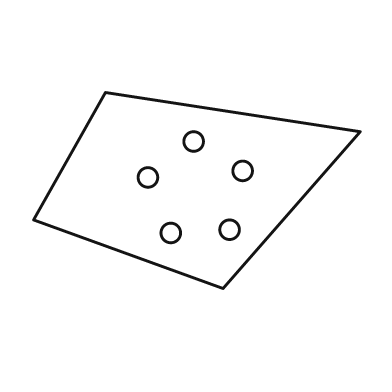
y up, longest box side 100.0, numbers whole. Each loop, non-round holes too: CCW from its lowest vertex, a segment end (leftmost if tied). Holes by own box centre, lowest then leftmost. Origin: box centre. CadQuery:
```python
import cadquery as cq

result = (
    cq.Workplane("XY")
    .moveTo(8.0, -30.0)
    .lineTo(50.0, 18.0)
    .lineTo(-28.0, 30.0)
    .lineTo(-50.0, -9.0)
    .close()
    .moveTo(-8.0, -13.0)
    .circle(3.0)
    .moveTo(10.0, -12.0)
    .circle(3.0)
    .moveTo(-15.0, 4.0)
    .circle(3.0)
    .moveTo(14.0, 6.0)
    .circle(3.0)
    .moveTo(-1.0, 15.0)
    .circle(3.0)
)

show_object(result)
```